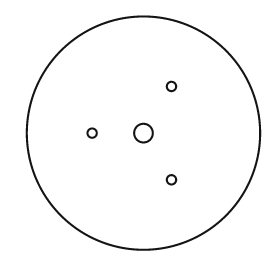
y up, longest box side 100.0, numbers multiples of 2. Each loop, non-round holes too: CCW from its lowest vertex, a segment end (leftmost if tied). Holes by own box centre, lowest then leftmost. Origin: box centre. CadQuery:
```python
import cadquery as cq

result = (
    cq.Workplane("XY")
    .moveTo(0.0, 0.0)
    .circle(50.0)
    .moveTo(12.0, -20.0)
    .circle(2.0)
    .moveTo(-22.0, 0.0)
    .circle(2.0)
    .moveTo(0.0, 0.0)
    .circle(4.0)
    .moveTo(12.0, 20.0)
    .circle(2.0)
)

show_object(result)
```